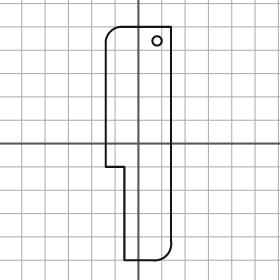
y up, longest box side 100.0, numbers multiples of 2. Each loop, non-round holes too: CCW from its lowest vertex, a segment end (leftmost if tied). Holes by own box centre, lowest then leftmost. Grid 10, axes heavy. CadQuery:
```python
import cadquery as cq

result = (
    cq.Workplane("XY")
    .moveTo(-6.0, -50.0)
    .lineTo(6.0, -50.0)
    .threePointArc((12.0, -48.0), (14.0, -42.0))
    .lineTo(14.0, 50.0)
    .lineTo(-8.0, 50.0)
    .threePointArc((-12.0, 48.0), (-14.0, 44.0))
    .lineTo(-14.0, -10.0)
    .lineTo(-6.0, -10.0)
    .close()
    .moveTo(8.0, 44.0)
    .circle(2.0)
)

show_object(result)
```